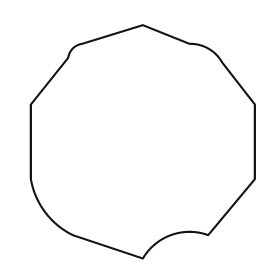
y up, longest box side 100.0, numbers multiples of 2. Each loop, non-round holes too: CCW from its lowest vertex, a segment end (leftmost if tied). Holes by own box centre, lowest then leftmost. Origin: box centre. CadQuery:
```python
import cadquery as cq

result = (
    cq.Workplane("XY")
    .moveTo(0.0, -50.0)
    .threePointArc((12.0, -40.0), (28.0, -40.0))
    .lineTo(48.0, -16.0)
    .lineTo(48.0, 16.0)
    .lineTo(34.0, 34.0)
    .threePointArc((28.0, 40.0), (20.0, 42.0))
    .lineTo(0.0, 50.0)
    .lineTo(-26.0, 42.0)
    .threePointArc((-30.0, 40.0), (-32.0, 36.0))
    .lineTo(-48.0, 16.0)
    .lineTo(-48.0, -16.0)
    .threePointArc((-42.0, -30.0), (-30.0, -40.0))
    .close()
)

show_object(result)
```